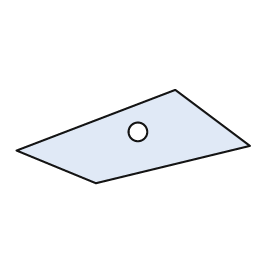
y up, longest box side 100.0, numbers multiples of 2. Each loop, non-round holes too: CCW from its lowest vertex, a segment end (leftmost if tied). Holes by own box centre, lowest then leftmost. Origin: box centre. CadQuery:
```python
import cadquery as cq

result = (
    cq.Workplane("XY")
    .moveTo(-16.0, -20.0)
    .lineTo(50.0, -4.0)
    .lineTo(18.0, 20.0)
    .lineTo(-50.0, -6.0)
    .close()
    .moveTo(2.0, 2.0)
    .circle(4.0)
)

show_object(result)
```